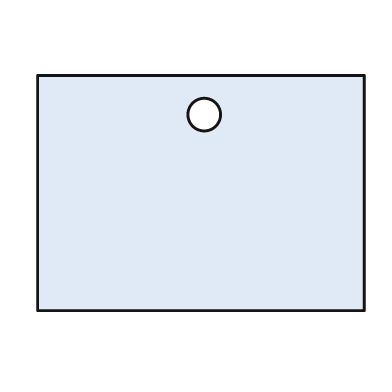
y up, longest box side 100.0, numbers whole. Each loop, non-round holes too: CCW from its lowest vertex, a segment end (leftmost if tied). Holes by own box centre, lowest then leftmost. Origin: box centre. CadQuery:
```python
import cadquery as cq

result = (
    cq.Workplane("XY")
    .moveTo(-50.0, -36.0)
    .lineTo(50.0, -36.0)
    .lineTo(50.0, 36.0)
    .lineTo(-50.0, 36.0)
    .close()
    .moveTo(1.0, 24.0)
    .circle(5.0)
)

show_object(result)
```